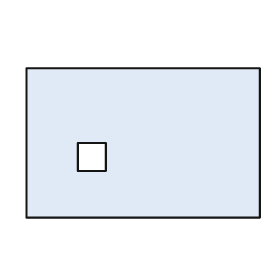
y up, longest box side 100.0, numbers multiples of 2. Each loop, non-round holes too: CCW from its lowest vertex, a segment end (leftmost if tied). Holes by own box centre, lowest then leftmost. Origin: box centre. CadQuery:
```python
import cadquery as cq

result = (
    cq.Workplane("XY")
    .moveTo(-50.0, -32.0)
    .lineTo(50.0, -32.0)
    .lineTo(50.0, 32.0)
    .lineTo(-50.0, 32.0)
    .close()
    .moveTo(-28.0, -12.0)
    .lineTo(-16.0, -12.0)
    .lineTo(-16.0, 0.0)
    .lineTo(-28.0, 0.0)
    .close()
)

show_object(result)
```